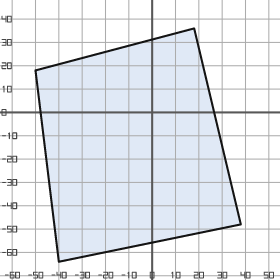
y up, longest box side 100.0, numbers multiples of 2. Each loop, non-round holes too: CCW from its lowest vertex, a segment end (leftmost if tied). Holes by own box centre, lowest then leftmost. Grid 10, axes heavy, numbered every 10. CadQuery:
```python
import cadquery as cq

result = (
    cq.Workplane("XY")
    .moveTo(-40.0, -64.0)
    .lineTo(38.0, -48.0)
    .lineTo(18.0, 36.0)
    .lineTo(-50.0, 18.0)
    .close()
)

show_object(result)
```